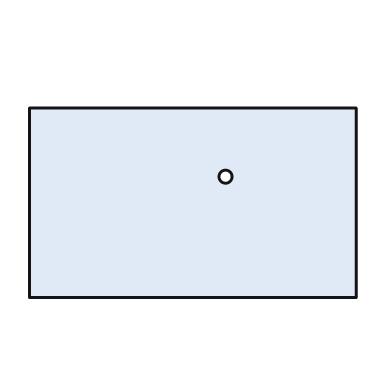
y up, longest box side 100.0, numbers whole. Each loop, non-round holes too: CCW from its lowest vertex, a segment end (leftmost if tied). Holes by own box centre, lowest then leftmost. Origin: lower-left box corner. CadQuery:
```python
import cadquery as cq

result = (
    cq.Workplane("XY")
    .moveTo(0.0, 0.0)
    .lineTo(100.0, 0.0)
    .lineTo(100.0, 58.0)
    .lineTo(0.0, 58.0)
    .close()
    .moveTo(60.0, 37.0)
    .circle(2.0)
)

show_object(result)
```